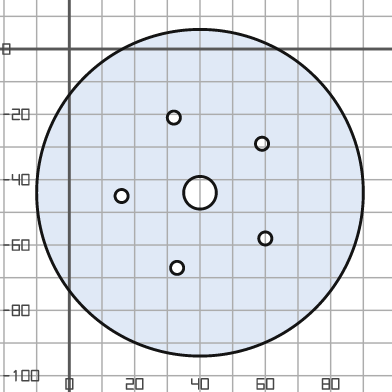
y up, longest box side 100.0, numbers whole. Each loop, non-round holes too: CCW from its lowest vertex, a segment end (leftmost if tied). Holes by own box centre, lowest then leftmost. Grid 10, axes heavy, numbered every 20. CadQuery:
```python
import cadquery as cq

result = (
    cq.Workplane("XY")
    .moveTo(40.0, -44.0)
    .circle(50.0)
    .moveTo(33.0, -67.0)
    .circle(2.0)
    .moveTo(60.0, -58.0)
    .circle(2.0)
    .moveTo(16.0, -45.0)
    .circle(2.0)
    .moveTo(40.0, -44.0)
    .circle(5.0)
    .moveTo(59.0, -29.0)
    .circle(2.0)
    .moveTo(32.0, -21.0)
    .circle(2.0)
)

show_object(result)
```